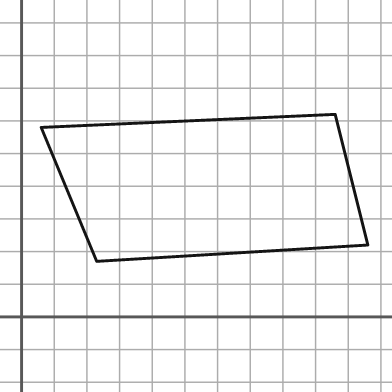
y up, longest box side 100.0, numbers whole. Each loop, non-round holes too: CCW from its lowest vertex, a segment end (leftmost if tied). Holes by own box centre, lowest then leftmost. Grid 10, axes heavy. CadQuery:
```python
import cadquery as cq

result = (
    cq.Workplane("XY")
    .moveTo(23.0, 17.0)
    .lineTo(106.0, 22.0)
    .lineTo(96.0, 62.0)
    .lineTo(6.0, 58.0)
    .close()
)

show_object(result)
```